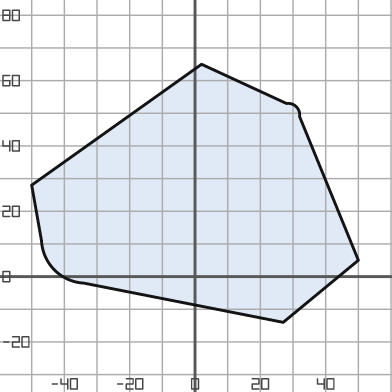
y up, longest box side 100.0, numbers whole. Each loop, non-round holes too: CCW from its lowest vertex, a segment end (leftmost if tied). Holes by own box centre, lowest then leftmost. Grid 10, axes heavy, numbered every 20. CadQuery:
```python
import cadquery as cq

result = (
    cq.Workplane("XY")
    .moveTo(27.0, -14.0)
    .lineTo(50.0, 5.0)
    .lineTo(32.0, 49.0)
    .threePointArc((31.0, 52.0), (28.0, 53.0))
    .lineTo(2.0, 65.0)
    .lineTo(-50.0, 28.0)
    .lineTo(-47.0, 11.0)
    .threePointArc((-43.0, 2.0), (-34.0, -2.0))
    .close()
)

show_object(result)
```